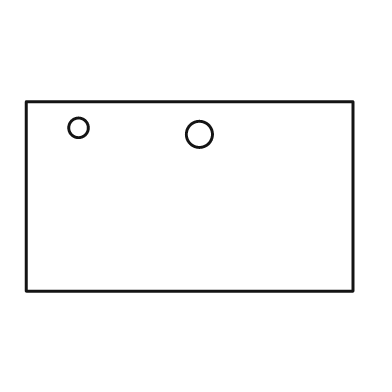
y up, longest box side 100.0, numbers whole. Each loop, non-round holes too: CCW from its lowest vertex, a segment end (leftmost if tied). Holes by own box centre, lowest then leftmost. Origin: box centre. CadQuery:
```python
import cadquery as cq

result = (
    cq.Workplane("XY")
    .moveTo(-50.0, -29.0)
    .lineTo(50.0, -29.0)
    .lineTo(50.0, 29.0)
    .lineTo(-50.0, 29.0)
    .close()
    .moveTo(3.0, 19.0)
    .circle(4.0)
    .moveTo(-34.0, 21.0)
    .circle(3.0)
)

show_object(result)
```